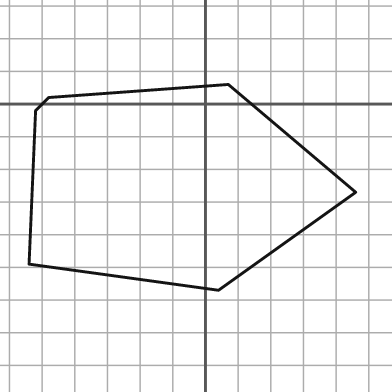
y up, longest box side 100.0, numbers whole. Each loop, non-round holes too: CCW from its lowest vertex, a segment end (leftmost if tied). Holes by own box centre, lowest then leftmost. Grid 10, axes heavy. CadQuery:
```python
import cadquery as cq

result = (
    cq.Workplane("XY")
    .moveTo(4.0, -57.0)
    .lineTo(46.0, -27.0)
    .lineTo(7.0, 6.0)
    .lineTo(-48.0, 2.0)
    .lineTo(-52.0, -2.0)
    .lineTo(-54.0, -49.0)
    .close()
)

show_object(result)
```